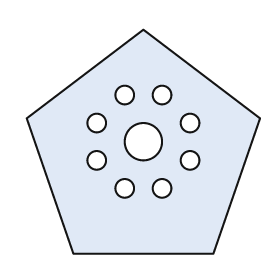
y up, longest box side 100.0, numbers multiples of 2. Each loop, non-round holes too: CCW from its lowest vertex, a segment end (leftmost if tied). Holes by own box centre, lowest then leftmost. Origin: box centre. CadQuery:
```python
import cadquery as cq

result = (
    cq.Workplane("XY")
    .moveTo(-30.0, -48.0)
    .lineTo(30.0, -48.0)
    .lineTo(50.0, 10.0)
    .lineTo(0.0, 48.0)
    .lineTo(-50.0, 10.0)
    .close()
    .moveTo(-8.0, -20.0)
    .circle(4.0)
    .moveTo(8.0, -20.0)
    .circle(4.0)
    .moveTo(-20.0, -8.0)
    .circle(4.0)
    .moveTo(20.0, -8.0)
    .circle(4.0)
    .moveTo(0.0, 0.0)
    .circle(8.0)
    .moveTo(-20.0, 8.0)
    .circle(4.0)
    .moveTo(20.0, 8.0)
    .circle(4.0)
    .moveTo(-8.0, 20.0)
    .circle(4.0)
    .moveTo(8.0, 20.0)
    .circle(4.0)
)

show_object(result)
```